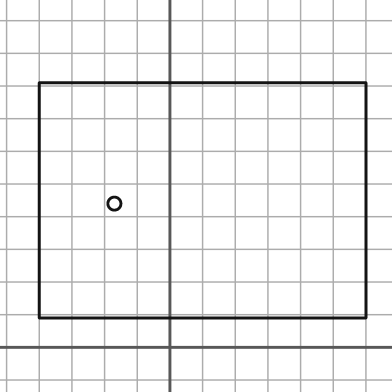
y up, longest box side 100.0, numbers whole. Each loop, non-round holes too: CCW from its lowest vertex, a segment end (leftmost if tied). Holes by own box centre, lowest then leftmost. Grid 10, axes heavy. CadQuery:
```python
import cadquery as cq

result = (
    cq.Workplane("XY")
    .moveTo(-40.0, 9.0)
    .lineTo(60.0, 9.0)
    .lineTo(60.0, 81.0)
    .lineTo(-40.0, 81.0)
    .close()
    .moveTo(-17.0, 44.0)
    .circle(2.0)
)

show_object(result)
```